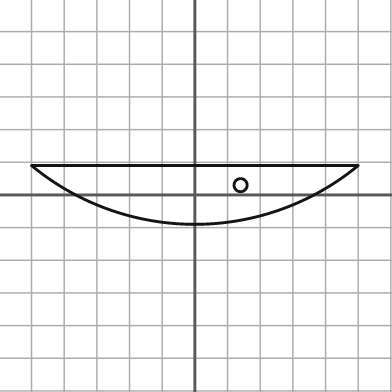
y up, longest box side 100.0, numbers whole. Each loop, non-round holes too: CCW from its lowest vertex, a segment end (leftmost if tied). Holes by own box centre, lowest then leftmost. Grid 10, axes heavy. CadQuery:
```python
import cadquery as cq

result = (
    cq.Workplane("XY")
    .moveTo(-50.0, 9.0)
    .threePointArc((0.0, -9.0), (50.0, 9.0))
    .close()
    .moveTo(14.0, 3.0)
    .circle(2.0)
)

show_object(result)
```